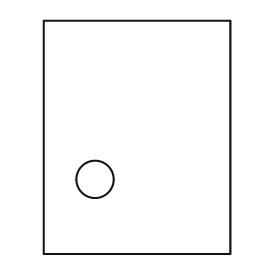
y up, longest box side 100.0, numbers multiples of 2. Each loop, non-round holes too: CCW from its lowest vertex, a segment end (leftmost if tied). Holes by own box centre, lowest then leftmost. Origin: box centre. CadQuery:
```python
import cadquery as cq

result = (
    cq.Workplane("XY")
    .moveTo(-40.0, -50.0)
    .lineTo(40.0, -50.0)
    .lineTo(40.0, 50.0)
    .lineTo(-40.0, 50.0)
    .close()
    .moveTo(-18.0, -18.0)
    .circle(8.0)
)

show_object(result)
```